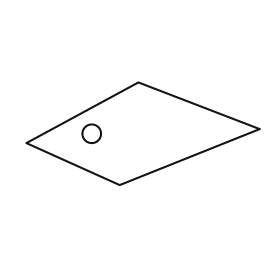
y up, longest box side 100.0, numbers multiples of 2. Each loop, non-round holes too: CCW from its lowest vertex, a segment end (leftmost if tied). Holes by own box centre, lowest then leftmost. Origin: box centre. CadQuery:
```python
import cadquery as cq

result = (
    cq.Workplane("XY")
    .moveTo(-10.0, -22.0)
    .lineTo(50.0, 2.0)
    .lineTo(-2.0, 22.0)
    .lineTo(-50.0, -4.0)
    .close()
    .moveTo(-22.0, 0.0)
    .circle(4.0)
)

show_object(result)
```